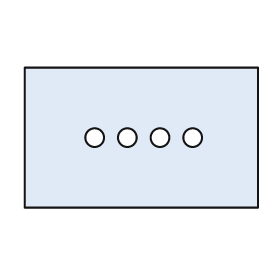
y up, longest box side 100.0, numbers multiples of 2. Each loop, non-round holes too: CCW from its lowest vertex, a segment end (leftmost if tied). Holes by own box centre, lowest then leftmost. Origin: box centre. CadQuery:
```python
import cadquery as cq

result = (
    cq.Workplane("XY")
    .moveTo(-50.0, -30.0)
    .lineTo(50.0, -30.0)
    .lineTo(50.0, 30.0)
    .lineTo(-50.0, 30.0)
    .close()
    .moveTo(-20.0, 0.0)
    .circle(4.0)
    .moveTo(-6.0, 0.0)
    .circle(4.0)
    .moveTo(8.0, 0.0)
    .circle(4.0)
    .moveTo(22.0, 0.0)
    .circle(4.0)
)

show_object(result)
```